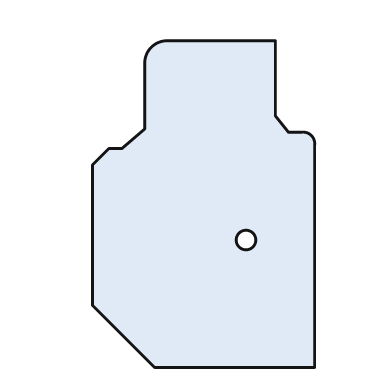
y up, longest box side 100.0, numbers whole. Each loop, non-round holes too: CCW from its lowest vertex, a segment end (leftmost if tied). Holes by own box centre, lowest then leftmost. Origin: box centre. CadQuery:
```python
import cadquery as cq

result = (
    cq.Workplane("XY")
    .moveTo(-15.0, -50.0)
    .lineTo(34.0, -50.0)
    .lineTo(34.0, 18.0)
    .threePointArc((33.0, 21.0), (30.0, 22.0))
    .lineTo(26.0, 22.0)
    .lineTo(22.0, 27.0)
    .lineTo(22.0, 50.0)
    .lineTo(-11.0, 50.0)
    .threePointArc((-16.0, 48.0), (-18.0, 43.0))
    .lineTo(-18.0, 23.0)
    .lineTo(-25.0, 17.0)
    .lineTo(-29.0, 17.0)
    .lineTo(-34.0, 12.0)
    .lineTo(-34.0, -31.0)
    .close()
    .moveTo(13.0, -11.0)
    .circle(3.0)
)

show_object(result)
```